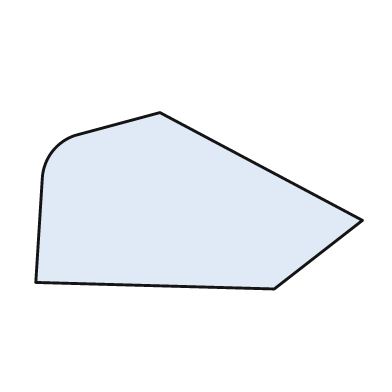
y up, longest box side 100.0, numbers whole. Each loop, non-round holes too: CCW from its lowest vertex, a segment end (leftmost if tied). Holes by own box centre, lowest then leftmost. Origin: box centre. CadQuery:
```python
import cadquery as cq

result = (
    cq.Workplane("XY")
    .moveTo(23.0, -27.0)
    .lineTo(50.0, -6.0)
    .lineTo(-12.0, 27.0)
    .lineTo(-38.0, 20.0)
    .threePointArc((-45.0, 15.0), (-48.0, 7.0))
    .lineTo(-50.0, -25.0)
    .close()
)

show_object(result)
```